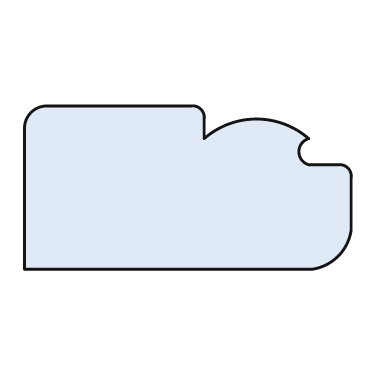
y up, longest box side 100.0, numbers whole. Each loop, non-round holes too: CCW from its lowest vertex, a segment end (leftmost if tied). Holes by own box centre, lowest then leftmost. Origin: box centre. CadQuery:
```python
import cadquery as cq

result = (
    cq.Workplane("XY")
    .moveTo(-50.0, -25.0)
    .lineTo(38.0, -25.0)
    .threePointArc((46.0, -21.0), (50.0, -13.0))
    .lineTo(50.0, 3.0)
    .threePointArc((49.0, 6.0), (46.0, 7.0))
    .lineTo(37.0, 7.0)
    .threePointArc((34.0, 11.0), (37.0, 15.0))
    .threePointArc((21.0, 21.0), (5.0, 15.0))
    .lineTo(5.0, 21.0)
    .threePointArc((4.0, 24.0), (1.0, 25.0))
    .lineTo(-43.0, 25.0)
    .threePointArc((-48.0, 23.0), (-50.0, 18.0))
    .close()
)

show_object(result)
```